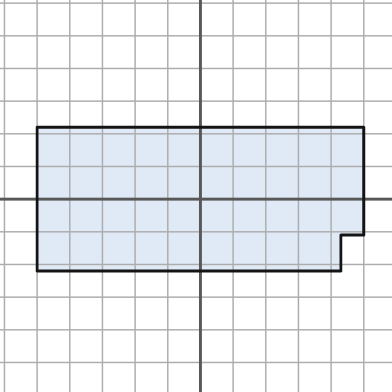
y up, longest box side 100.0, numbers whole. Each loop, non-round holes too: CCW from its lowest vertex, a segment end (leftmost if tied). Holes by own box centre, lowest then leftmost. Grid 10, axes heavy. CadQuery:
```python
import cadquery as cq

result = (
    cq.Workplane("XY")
    .moveTo(-50.0, -22.0)
    .lineTo(43.0, -22.0)
    .lineTo(43.0, -11.0)
    .lineTo(50.0, -11.0)
    .lineTo(50.0, 22.0)
    .lineTo(-50.0, 22.0)
    .close()
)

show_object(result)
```